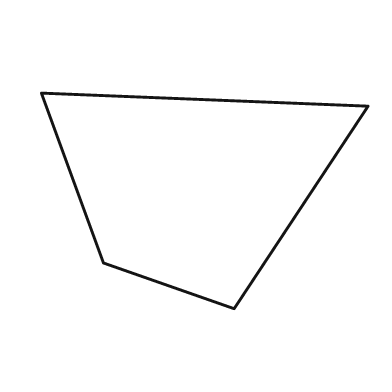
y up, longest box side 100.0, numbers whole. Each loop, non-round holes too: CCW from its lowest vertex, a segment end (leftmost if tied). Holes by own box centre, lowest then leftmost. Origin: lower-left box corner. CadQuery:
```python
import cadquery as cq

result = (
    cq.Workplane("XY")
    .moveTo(59.0, 0.0)
    .lineTo(100.0, 62.0)
    .lineTo(0.0, 66.0)
    .lineTo(19.0, 14.0)
    .close()
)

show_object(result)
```